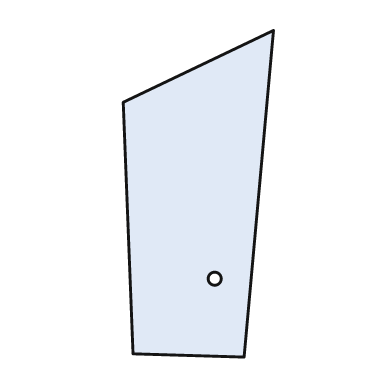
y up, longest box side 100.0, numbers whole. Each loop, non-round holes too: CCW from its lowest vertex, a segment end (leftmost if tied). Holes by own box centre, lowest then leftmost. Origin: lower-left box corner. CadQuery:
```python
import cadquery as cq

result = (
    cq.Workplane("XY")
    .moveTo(37.0, 0.0)
    .lineTo(46.0, 100.0)
    .lineTo(0.0, 78.0)
    .lineTo(3.0, 1.0)
    .close()
    .moveTo(28.0, 24.0)
    .circle(2.0)
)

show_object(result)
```